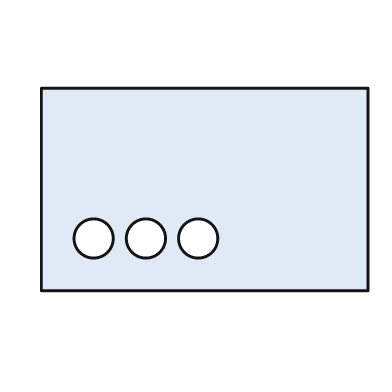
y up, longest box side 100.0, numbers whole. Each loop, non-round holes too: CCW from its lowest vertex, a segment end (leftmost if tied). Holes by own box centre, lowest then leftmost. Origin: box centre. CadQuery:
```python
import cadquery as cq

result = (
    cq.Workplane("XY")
    .moveTo(-50.0, -31.0)
    .lineTo(50.0, -31.0)
    .lineTo(50.0, 31.0)
    .lineTo(-50.0, 31.0)
    .close()
    .moveTo(-34.0, -15.0)
    .circle(6.0)
    .moveTo(-18.0, -15.0)
    .circle(6.0)
    .moveTo(-2.0, -15.0)
    .circle(6.0)
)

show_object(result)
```